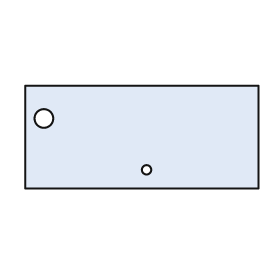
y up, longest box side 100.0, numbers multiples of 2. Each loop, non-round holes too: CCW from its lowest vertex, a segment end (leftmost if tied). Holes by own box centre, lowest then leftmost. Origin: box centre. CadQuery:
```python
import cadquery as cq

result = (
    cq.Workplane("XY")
    .moveTo(-50.0, -22.0)
    .lineTo(50.0, -22.0)
    .lineTo(50.0, 22.0)
    .lineTo(-50.0, 22.0)
    .close()
    .moveTo(2.0, -14.0)
    .circle(2.0)
    .moveTo(-42.0, 8.0)
    .circle(4.0)
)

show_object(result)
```